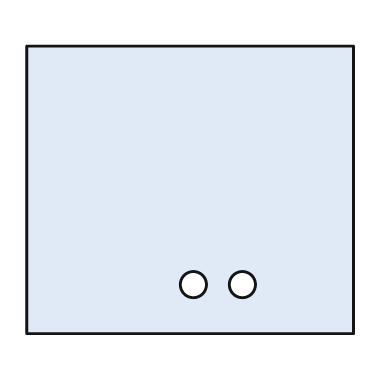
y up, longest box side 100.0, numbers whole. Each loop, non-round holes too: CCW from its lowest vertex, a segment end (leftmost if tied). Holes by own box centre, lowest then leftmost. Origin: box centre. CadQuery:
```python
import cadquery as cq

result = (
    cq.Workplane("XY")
    .moveTo(-50.0, -44.0)
    .lineTo(50.0, -44.0)
    .lineTo(50.0, 44.0)
    .lineTo(-50.0, 44.0)
    .close()
    .moveTo(1.0, -29.0)
    .circle(4.0)
    .moveTo(16.0, -29.0)
    .circle(4.0)
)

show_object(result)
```